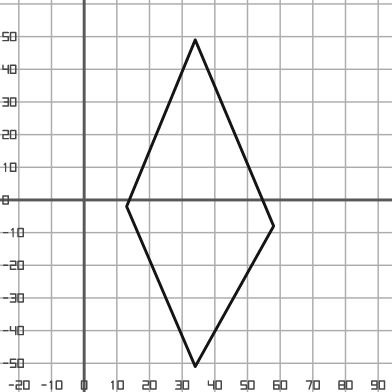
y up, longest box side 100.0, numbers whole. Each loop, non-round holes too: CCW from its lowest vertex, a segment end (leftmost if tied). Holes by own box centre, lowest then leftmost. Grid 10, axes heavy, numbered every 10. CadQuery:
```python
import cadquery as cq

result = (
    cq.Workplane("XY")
    .moveTo(34.0, -51.0)
    .lineTo(58.0, -8.0)
    .lineTo(34.0, 49.0)
    .lineTo(13.0, -2.0)
    .close()
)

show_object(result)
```